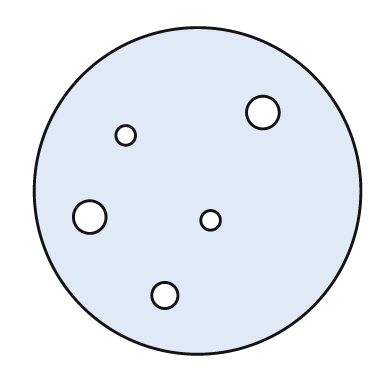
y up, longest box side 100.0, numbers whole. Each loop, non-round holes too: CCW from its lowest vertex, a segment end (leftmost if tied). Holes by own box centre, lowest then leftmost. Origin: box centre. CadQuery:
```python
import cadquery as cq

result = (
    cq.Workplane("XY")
    .moveTo(0.0, 0.0)
    .circle(50.0)
    .moveTo(-10.0, -32.0)
    .circle(4.0)
    .moveTo(4.0, -9.0)
    .circle(3.0)
    .moveTo(-33.0, -8.0)
    .circle(5.0)
    .moveTo(-22.0, 17.0)
    .circle(3.0)
    .moveTo(20.0, 24.0)
    .circle(5.0)
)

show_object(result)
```